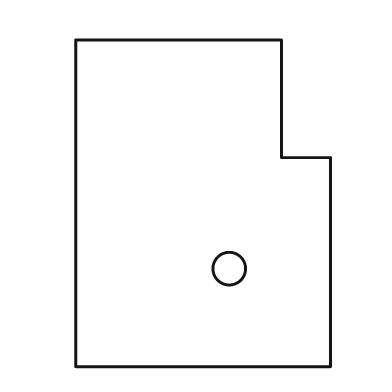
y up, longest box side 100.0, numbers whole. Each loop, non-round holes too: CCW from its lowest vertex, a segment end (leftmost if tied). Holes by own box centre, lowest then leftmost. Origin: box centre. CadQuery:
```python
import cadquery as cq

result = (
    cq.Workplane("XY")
    .moveTo(-39.0, -50.0)
    .lineTo(39.0, -50.0)
    .lineTo(39.0, 14.0)
    .lineTo(24.0, 14.0)
    .lineTo(24.0, 50.0)
    .lineTo(-39.0, 50.0)
    .close()
    .moveTo(8.0, -20.0)
    .circle(5.0)
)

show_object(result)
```